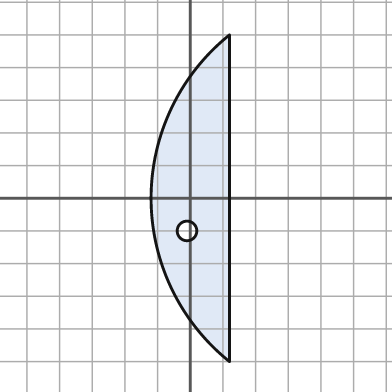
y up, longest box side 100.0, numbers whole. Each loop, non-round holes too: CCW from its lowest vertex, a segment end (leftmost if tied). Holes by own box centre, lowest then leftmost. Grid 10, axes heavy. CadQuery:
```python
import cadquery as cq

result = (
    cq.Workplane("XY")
    .moveTo(12.0, -50.0)
    .lineTo(12.0, 50.0)
    .threePointArc((-12.0, 0.0), (12.0, -50.0))
    .close()
    .moveTo(-1.0, -10.0)
    .circle(3.0)
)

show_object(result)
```